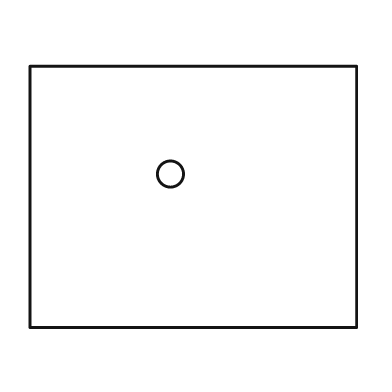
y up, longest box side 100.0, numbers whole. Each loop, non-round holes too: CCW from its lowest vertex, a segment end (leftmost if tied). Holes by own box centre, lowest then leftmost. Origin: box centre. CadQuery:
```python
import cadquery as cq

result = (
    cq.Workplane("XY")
    .moveTo(-50.0, -40.0)
    .lineTo(50.0, -40.0)
    .lineTo(50.0, 40.0)
    .lineTo(-50.0, 40.0)
    .close()
    .moveTo(-7.0, 7.0)
    .circle(4.0)
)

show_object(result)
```